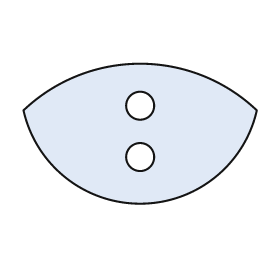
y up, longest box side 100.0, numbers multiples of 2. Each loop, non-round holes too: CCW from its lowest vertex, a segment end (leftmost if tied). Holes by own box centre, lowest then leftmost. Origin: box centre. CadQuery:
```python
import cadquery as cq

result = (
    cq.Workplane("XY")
    .moveTo(-50.0, 10.0)
    .threePointArc((0.0, -30.0), (50.0, 10.0))
    .threePointArc((0.0, 30.0), (-50.0, 10.0))
    .close()
    .moveTo(0.0, -10.0)
    .circle(6.0)
    .moveTo(0.0, 12.0)
    .circle(6.0)
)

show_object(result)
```